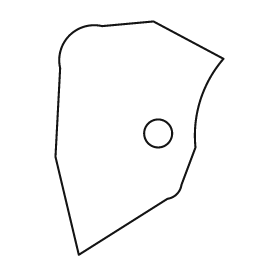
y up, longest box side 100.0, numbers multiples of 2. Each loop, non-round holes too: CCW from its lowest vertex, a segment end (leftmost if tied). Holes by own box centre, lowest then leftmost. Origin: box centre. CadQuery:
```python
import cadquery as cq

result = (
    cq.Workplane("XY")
    .moveTo(-26.0, -50.0)
    .lineTo(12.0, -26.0)
    .threePointArc((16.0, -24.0), (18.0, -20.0))
    .lineTo(24.0, -4.0)
    .threePointArc((26.0, 16.0), (36.0, 34.0))
    .lineTo(6.0, 50.0)
    .lineTo(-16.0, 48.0)
    .threePointArc((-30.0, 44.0), (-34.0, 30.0))
    .lineTo(-36.0, -8.0)
    .close()
    .moveTo(8.0, 2.0)
    .circle(6.0)
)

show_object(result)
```